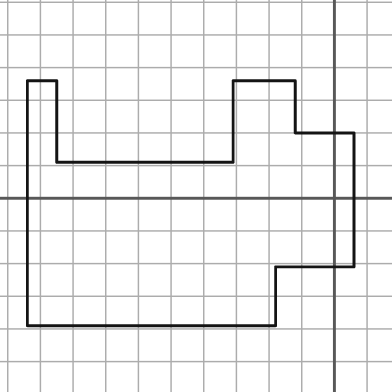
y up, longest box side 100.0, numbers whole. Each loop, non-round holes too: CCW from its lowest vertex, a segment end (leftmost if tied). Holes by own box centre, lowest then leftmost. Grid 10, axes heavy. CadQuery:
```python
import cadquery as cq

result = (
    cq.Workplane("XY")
    .moveTo(-94.0, -39.0)
    .lineTo(-18.0, -39.0)
    .lineTo(-18.0, -21.0)
    .lineTo(6.0, -21.0)
    .lineTo(6.0, 20.0)
    .lineTo(-12.0, 20.0)
    .lineTo(-12.0, 36.0)
    .lineTo(-31.0, 36.0)
    .lineTo(-31.0, 11.0)
    .lineTo(-85.0, 11.0)
    .lineTo(-85.0, 36.0)
    .lineTo(-94.0, 36.0)
    .close()
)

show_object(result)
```